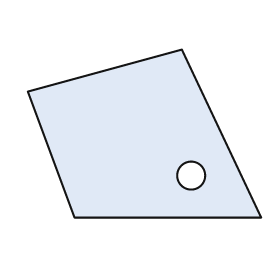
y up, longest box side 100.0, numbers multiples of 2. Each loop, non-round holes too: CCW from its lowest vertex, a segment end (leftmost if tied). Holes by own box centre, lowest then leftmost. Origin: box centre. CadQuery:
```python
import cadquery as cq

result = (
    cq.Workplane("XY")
    .moveTo(-30.0, -36.0)
    .lineTo(50.0, -36.0)
    .lineTo(16.0, 36.0)
    .lineTo(-50.0, 18.0)
    .close()
    .moveTo(20.0, -18.0)
    .circle(6.0)
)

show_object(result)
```